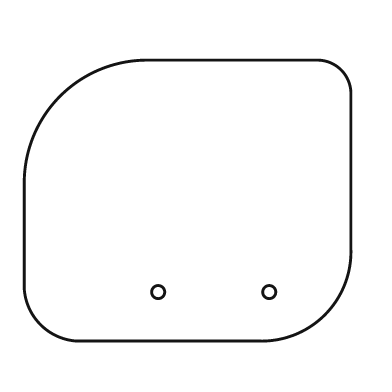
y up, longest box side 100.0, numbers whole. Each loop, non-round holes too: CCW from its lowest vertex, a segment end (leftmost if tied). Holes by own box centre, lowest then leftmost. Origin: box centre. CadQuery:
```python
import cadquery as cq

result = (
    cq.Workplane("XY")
    .moveTo(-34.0, -43.0)
    .lineTo(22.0, -43.0)
    .threePointArc((42.0, -35.0), (50.0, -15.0))
    .lineTo(50.0, 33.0)
    .threePointArc((47.0, 40.0), (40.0, 43.0))
    .lineTo(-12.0, 43.0)
    .threePointArc((-39.0, 32.0), (-50.0, 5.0))
    .lineTo(-50.0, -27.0)
    .threePointArc((-45.0, -38.0), (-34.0, -43.0))
    .close()
    .moveTo(-9.0, -28.0)
    .circle(2.0)
    .moveTo(25.0, -28.0)
    .circle(2.0)
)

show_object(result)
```